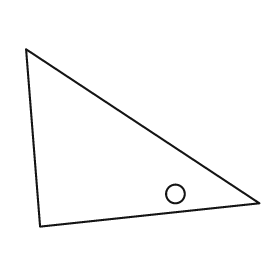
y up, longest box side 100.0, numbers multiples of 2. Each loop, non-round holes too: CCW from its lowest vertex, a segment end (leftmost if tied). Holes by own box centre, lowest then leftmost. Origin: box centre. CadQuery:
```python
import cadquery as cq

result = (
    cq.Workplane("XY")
    .moveTo(-44.0, -38.0)
    .lineTo(50.0, -28.0)
    .lineTo(-50.0, 38.0)
    .close()
    .moveTo(14.0, -24.0)
    .circle(4.0)
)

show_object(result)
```